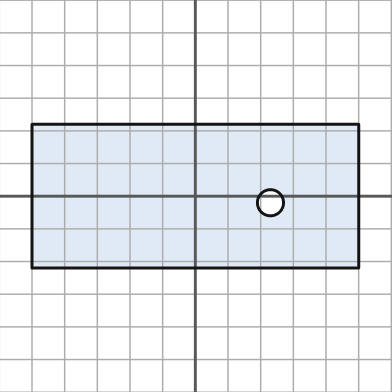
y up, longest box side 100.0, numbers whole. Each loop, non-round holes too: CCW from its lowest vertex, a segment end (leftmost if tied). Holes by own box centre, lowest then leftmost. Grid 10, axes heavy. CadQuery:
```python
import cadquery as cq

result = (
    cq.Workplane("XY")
    .moveTo(-50.0, -22.0)
    .lineTo(50.0, -22.0)
    .lineTo(50.0, 22.0)
    .lineTo(-50.0, 22.0)
    .close()
    .moveTo(23.0, -2.0)
    .circle(4.0)
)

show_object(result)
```